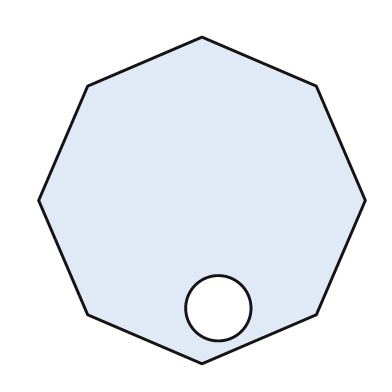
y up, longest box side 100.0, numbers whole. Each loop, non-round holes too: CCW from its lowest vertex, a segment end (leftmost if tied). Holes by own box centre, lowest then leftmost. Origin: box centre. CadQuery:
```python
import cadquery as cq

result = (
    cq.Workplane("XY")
    .moveTo(0.0, -50.0)
    .lineTo(35.0, -35.0)
    .lineTo(50.0, 0.0)
    .lineTo(35.0, 35.0)
    .lineTo(0.0, 50.0)
    .lineTo(-35.0, 35.0)
    .lineTo(-50.0, 0.0)
    .lineTo(-35.0, -35.0)
    .close()
    .moveTo(5.0, -33.0)
    .circle(10.0)
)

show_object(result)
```